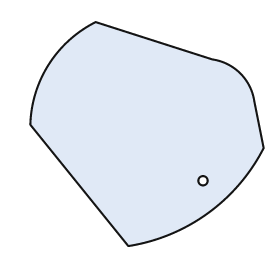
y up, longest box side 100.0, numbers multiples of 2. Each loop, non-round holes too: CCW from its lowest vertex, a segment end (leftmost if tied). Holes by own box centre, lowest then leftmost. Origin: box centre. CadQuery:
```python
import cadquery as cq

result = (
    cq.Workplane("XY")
    .moveTo(-8.0, -48.0)
    .threePointArc((26.0, -34.0), (50.0, -6.0))
    .lineTo(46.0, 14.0)
    .threePointArc((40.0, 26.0), (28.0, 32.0))
    .lineTo(-22.0, 48.0)
    .threePointArc((-42.0, 30.0), (-50.0, 4.0))
    .close()
    .moveTo(24.0, -20.0)
    .circle(2.0)
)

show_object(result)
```